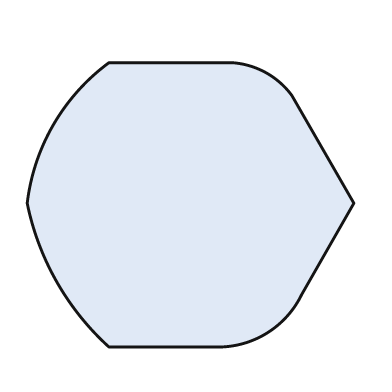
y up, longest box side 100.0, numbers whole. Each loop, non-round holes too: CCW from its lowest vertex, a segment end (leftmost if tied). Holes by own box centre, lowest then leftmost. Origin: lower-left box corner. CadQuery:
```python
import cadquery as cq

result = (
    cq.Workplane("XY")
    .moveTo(25.0, 0.0)
    .lineTo(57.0, 0.0)
    .threePointArc((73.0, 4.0), (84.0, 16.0))
    .lineTo(100.0, 44.0)
    .lineTo(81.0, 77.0)
    .threePointArc((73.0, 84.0), (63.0, 87.0))
    .lineTo(25.0, 87.0)
    .threePointArc((8.0, 68.0), (0.0, 44.0))
    .threePointArc((9.0, 20.0), (25.0, 0.0))
    .close()
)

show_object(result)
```